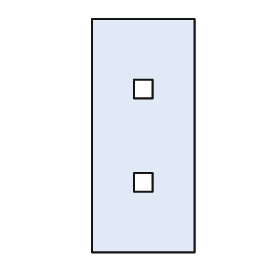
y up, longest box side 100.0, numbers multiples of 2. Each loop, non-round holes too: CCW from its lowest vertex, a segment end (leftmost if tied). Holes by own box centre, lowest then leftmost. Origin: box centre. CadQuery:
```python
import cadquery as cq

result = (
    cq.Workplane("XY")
    .moveTo(-22.0, -50.0)
    .lineTo(22.0, -50.0)
    .lineTo(22.0, 50.0)
    .lineTo(-22.0, 50.0)
    .close()
    .moveTo(-4.0, -24.0)
    .lineTo(4.0, -24.0)
    .lineTo(4.0, -16.0)
    .lineTo(-4.0, -16.0)
    .close()
    .moveTo(-4.0, 16.0)
    .lineTo(4.0, 16.0)
    .lineTo(4.0, 24.0)
    .lineTo(-4.0, 24.0)
    .close()
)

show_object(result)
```